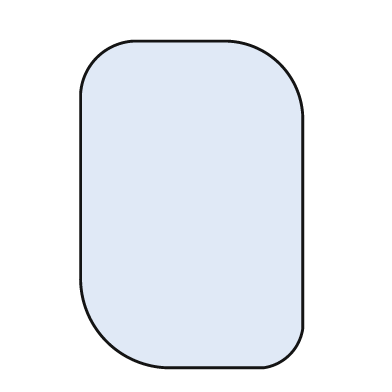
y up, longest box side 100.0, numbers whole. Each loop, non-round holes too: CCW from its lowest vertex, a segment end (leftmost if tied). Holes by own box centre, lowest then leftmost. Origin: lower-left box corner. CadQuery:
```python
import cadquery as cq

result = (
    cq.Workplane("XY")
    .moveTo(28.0, 0.0)
    .lineTo(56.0, 0.0)
    .threePointArc((64.0, 4.0), (68.0, 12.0))
    .lineTo(68.0, 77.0)
    .threePointArc((61.0, 93.0), (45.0, 100.0))
    .lineTo(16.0, 100.0)
    .threePointArc((5.0, 95.0), (0.0, 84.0))
    .lineTo(0.0, 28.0)
    .threePointArc((8.0, 8.0), (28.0, 0.0))
    .close()
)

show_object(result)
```